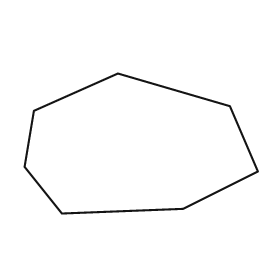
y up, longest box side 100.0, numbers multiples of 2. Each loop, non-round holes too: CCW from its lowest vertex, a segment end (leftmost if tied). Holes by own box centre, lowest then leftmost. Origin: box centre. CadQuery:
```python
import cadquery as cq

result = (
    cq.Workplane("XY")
    .moveTo(-34.0, -30.0)
    .lineTo(18.0, -28.0)
    .lineTo(50.0, -12.0)
    .lineTo(38.0, 16.0)
    .lineTo(-10.0, 30.0)
    .lineTo(-46.0, 14.0)
    .lineTo(-50.0, -10.0)
    .close()
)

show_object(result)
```